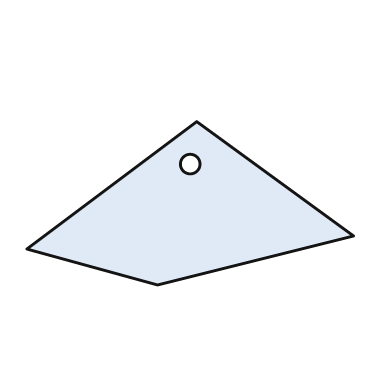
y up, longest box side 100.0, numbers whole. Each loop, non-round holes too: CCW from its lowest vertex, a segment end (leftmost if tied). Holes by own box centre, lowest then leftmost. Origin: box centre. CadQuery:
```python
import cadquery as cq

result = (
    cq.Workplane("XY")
    .moveTo(-10.0, -25.0)
    .lineTo(50.0, -10.0)
    .lineTo(2.0, 25.0)
    .lineTo(-50.0, -14.0)
    .close()
    .moveTo(0.0, 12.0)
    .circle(3.0)
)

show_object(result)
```